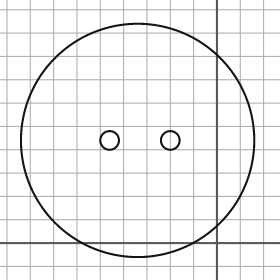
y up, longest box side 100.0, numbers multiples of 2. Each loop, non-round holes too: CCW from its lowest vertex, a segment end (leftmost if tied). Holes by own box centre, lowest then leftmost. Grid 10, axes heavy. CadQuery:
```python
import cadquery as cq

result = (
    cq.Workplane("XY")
    .moveTo(-34.0, 44.0)
    .circle(50.0)
    .moveTo(-46.0, 44.0)
    .circle(4.0)
    .moveTo(-20.0, 44.0)
    .circle(4.0)
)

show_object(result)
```